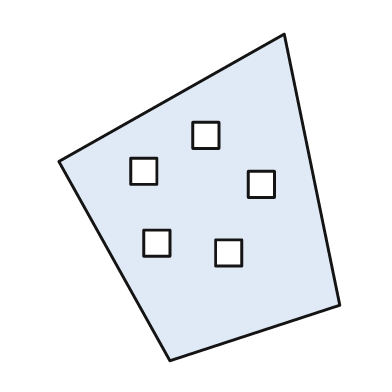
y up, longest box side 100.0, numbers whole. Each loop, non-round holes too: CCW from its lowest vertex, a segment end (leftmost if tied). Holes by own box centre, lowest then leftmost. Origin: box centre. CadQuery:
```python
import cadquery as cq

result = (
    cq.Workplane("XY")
    .moveTo(-9.0, -50.0)
    .lineTo(43.0, -33.0)
    .lineTo(26.0, 50.0)
    .lineTo(-43.0, 11.0)
    .close()
    .moveTo(5.0, -21.0)
    .lineTo(13.0, -21.0)
    .lineTo(13.0, -13.0)
    .lineTo(5.0, -13.0)
    .close()
    .moveTo(-17.0, -18.0)
    .lineTo(-9.0, -18.0)
    .lineTo(-9.0, -10.0)
    .lineTo(-17.0, -10.0)
    .close()
    .moveTo(15.0, 0.0)
    .lineTo(23.0, 0.0)
    .lineTo(23.0, 8.0)
    .lineTo(15.0, 8.0)
    .close()
    .moveTo(-21.0, 4.0)
    .lineTo(-13.0, 4.0)
    .lineTo(-13.0, 12.0)
    .lineTo(-21.0, 12.0)
    .close()
    .moveTo(-2.0, 15.0)
    .lineTo(6.0, 15.0)
    .lineTo(6.0, 23.0)
    .lineTo(-2.0, 23.0)
    .close()
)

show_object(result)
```